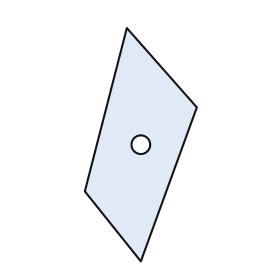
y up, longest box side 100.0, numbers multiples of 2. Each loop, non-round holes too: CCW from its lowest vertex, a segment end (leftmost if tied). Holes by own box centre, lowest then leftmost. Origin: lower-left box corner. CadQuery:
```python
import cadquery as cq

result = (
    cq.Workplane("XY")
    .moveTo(24.0, 0.0)
    .lineTo(48.0, 66.0)
    .lineTo(18.0, 100.0)
    .lineTo(0.0, 30.0)
    .close()
    .moveTo(24.0, 50.0)
    .circle(4.0)
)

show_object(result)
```